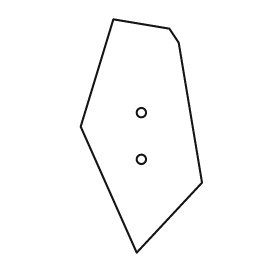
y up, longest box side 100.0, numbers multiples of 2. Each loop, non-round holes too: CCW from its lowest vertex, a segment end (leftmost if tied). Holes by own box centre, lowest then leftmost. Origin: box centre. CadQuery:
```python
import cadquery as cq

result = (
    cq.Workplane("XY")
    .moveTo(-2.0, -50.0)
    .lineTo(26.0, -20.0)
    .lineTo(16.0, 40.0)
    .lineTo(12.0, 46.0)
    .lineTo(-12.0, 50.0)
    .lineTo(-26.0, 4.0)
    .close()
    .moveTo(0.0, -10.0)
    .circle(2.0)
    .moveTo(0.0, 10.0)
    .circle(2.0)
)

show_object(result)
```